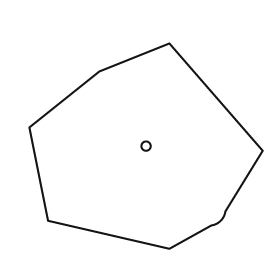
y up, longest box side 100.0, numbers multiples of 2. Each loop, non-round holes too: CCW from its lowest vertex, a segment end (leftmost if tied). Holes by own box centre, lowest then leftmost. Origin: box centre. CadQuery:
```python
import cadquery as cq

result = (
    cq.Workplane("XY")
    .moveTo(10.0, -44.0)
    .lineTo(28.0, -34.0)
    .threePointArc((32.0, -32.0), (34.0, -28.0))
    .lineTo(50.0, -2.0)
    .lineTo(10.0, 44.0)
    .lineTo(-20.0, 32.0)
    .lineTo(-50.0, 8.0)
    .lineTo(-42.0, -32.0)
    .close()
    .moveTo(0.0, 0.0)
    .circle(2.0)
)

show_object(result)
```